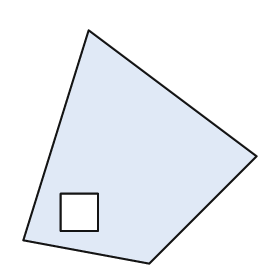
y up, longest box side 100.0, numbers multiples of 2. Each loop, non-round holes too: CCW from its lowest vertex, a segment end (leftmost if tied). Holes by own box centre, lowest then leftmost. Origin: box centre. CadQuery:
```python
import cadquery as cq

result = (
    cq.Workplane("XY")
    .moveTo(4.0, -50.0)
    .lineTo(50.0, -4.0)
    .lineTo(-22.0, 50.0)
    .lineTo(-50.0, -40.0)
    .close()
    .moveTo(-34.0, -36.0)
    .lineTo(-18.0, -36.0)
    .lineTo(-18.0, -20.0)
    .lineTo(-34.0, -20.0)
    .close()
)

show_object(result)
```